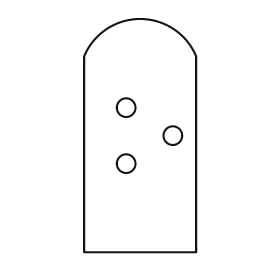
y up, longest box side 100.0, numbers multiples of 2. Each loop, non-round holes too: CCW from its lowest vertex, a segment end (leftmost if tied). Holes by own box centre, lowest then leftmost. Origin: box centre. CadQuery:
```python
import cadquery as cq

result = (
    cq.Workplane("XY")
    .moveTo(-24.0, -50.0)
    .lineTo(24.0, -50.0)
    .lineTo(24.0, 34.0)
    .threePointArc((0.0, 50.0), (-24.0, 34.0))
    .close()
    .moveTo(-6.0, -12.0)
    .circle(4.0)
    .moveTo(14.0, 0.0)
    .circle(4.0)
    .moveTo(-6.0, 12.0)
    .circle(4.0)
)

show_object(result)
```